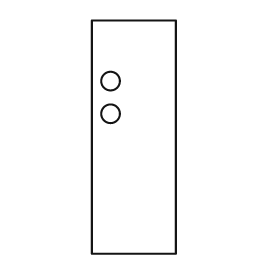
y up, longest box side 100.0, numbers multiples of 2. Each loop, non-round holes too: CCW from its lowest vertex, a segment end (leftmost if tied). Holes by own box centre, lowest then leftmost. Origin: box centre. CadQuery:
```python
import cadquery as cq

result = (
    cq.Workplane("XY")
    .moveTo(-18.0, -50.0)
    .lineTo(18.0, -50.0)
    .lineTo(18.0, 50.0)
    .lineTo(-18.0, 50.0)
    .close()
    .moveTo(-10.0, 10.0)
    .circle(4.0)
    .moveTo(-10.0, 24.0)
    .circle(4.0)
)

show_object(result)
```